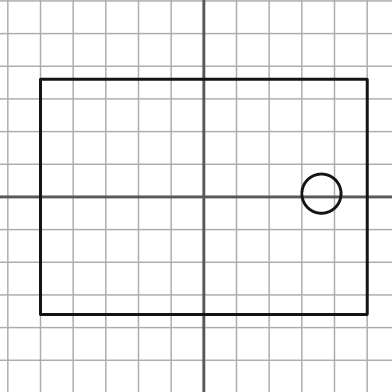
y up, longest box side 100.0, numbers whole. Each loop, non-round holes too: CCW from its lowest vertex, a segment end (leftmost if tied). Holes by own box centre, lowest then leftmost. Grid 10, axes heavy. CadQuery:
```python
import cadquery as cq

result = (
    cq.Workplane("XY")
    .moveTo(-50.0, -36.0)
    .lineTo(50.0, -36.0)
    .lineTo(50.0, 36.0)
    .lineTo(-50.0, 36.0)
    .close()
    .moveTo(36.0, 1.0)
    .circle(6.0)
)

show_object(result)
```